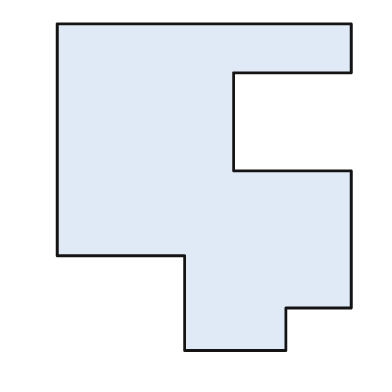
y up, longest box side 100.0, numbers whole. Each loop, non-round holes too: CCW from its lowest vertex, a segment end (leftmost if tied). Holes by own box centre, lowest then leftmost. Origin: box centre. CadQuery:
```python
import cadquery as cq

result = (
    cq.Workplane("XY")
    .moveTo(-6.0, -50.0)
    .lineTo(25.0, -50.0)
    .lineTo(25.0, -37.0)
    .lineTo(45.0, -37.0)
    .lineTo(45.0, 5.0)
    .lineTo(9.0, 5.0)
    .lineTo(9.0, 35.0)
    .lineTo(45.0, 35.0)
    .lineTo(45.0, 50.0)
    .lineTo(-45.0, 50.0)
    .lineTo(-45.0, -21.0)
    .lineTo(-6.0, -21.0)
    .close()
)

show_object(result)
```